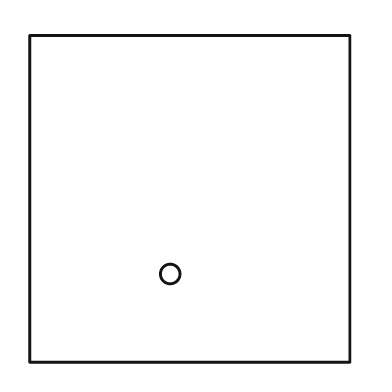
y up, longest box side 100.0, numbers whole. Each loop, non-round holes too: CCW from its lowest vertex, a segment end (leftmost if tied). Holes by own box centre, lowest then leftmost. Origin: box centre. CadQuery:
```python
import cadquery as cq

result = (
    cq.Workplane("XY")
    .moveTo(-49.0, -50.0)
    .lineTo(49.0, -50.0)
    .lineTo(49.0, 50.0)
    .lineTo(-49.0, 50.0)
    .close()
    .moveTo(-6.0, -23.0)
    .circle(3.0)
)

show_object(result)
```